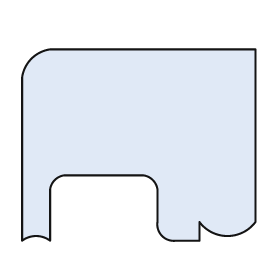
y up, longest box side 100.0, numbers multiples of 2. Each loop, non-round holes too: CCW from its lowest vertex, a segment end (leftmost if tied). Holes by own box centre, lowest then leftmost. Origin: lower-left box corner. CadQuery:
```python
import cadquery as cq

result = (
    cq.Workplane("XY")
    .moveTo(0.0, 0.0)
    .threePointArc((6.0, 2.0), (12.0, 0.0))
    .lineTo(12.0, 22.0)
    .threePointArc((14.0, 26.0), (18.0, 28.0))
    .lineTo(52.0, 28.0)
    .threePointArc((56.0, 26.0), (58.0, 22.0))
    .lineTo(58.0, 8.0)
    .threePointArc((60.0, 2.0), (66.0, 0.0))
    .lineTo(76.0, 0.0)
    .lineTo(76.0, 8.0)
    .threePointArc((88.0, 2.0), (100.0, 8.0))
    .lineTo(100.0, 82.0)
    .lineTo(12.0, 82.0)
    .threePointArc((4.0, 78.0), (0.0, 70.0))
    .close()
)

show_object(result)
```